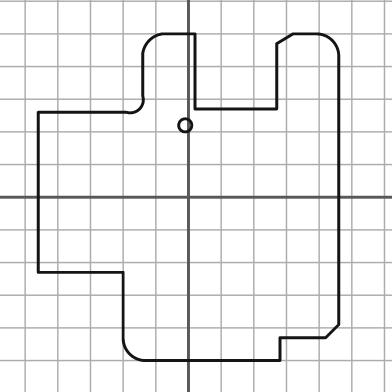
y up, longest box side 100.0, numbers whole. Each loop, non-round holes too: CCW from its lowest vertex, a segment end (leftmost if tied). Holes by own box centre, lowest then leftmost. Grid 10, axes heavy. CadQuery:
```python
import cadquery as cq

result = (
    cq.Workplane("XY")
    .moveTo(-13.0, -50.0)
    .lineTo(28.0, -50.0)
    .lineTo(28.0, -43.0)
    .lineTo(42.0, -43.0)
    .lineTo(46.0, -39.0)
    .lineTo(46.0, 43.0)
    .threePointArc((44.0, 48.0), (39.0, 50.0))
    .lineTo(32.0, 50.0)
    .lineTo(27.0, 47.0)
    .lineTo(27.0, 27.0)
    .lineTo(2.0, 27.0)
    .lineTo(2.0, 50.0)
    .lineTo(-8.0, 50.0)
    .threePointArc((-12.0, 48.0), (-14.0, 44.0))
    .lineTo(-14.0, 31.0)
    .threePointArc((-15.0, 27.0), (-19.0, 26.0))
    .lineTo(-46.0, 26.0)
    .lineTo(-46.0, -23.0)
    .lineTo(-20.0, -23.0)
    .lineTo(-20.0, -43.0)
    .threePointArc((-18.0, -48.0), (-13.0, -50.0))
    .close()
    .moveTo(-1.0, 22.0)
    .circle(2.0)
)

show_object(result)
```